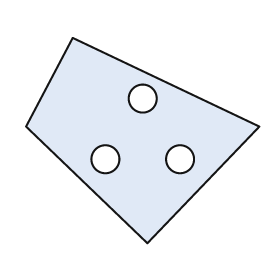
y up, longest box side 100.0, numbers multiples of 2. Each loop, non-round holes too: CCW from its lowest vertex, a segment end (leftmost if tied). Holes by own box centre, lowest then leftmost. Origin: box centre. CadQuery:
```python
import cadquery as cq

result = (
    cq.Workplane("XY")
    .moveTo(2.0, -44.0)
    .lineTo(50.0, 6.0)
    .lineTo(-30.0, 44.0)
    .lineTo(-50.0, 6.0)
    .close()
    .moveTo(-16.0, -8.0)
    .circle(6.0)
    .moveTo(16.0, -8.0)
    .circle(6.0)
    .moveTo(0.0, 18.0)
    .circle(6.0)
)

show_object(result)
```